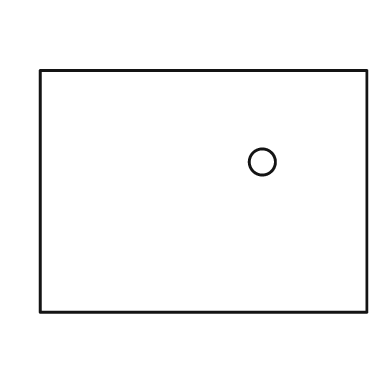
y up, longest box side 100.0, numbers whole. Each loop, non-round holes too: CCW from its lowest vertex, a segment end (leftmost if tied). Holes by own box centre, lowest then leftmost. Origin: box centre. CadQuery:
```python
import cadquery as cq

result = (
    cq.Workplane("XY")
    .moveTo(-50.0, -37.0)
    .lineTo(50.0, -37.0)
    .lineTo(50.0, 37.0)
    .lineTo(-50.0, 37.0)
    .close()
    .moveTo(18.0, 9.0)
    .circle(4.0)
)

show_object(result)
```